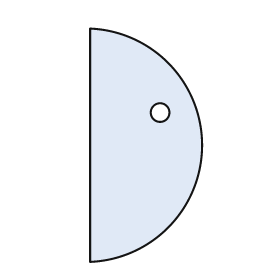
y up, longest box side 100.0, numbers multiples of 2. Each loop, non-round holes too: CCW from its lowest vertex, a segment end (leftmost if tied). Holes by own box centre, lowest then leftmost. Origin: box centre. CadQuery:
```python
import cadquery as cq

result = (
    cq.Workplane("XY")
    .moveTo(-24.0, -50.0)
    .threePointArc((24.0, 0.0), (-24.0, 50.0))
    .close()
    .moveTo(6.0, 14.0)
    .circle(4.0)
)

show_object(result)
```